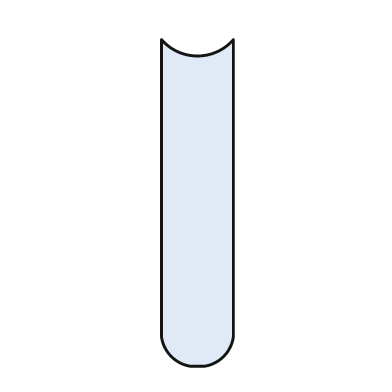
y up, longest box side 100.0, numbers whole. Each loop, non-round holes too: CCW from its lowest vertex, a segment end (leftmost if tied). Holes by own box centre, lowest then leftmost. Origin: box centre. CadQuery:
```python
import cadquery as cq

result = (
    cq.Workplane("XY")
    .moveTo(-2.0, -50.0)
    .lineTo(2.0, -50.0)
    .threePointArc((8.0, -47.0), (11.0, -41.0))
    .lineTo(11.0, 50.0)
    .threePointArc((0.0, 45.0), (-11.0, 50.0))
    .lineTo(-11.0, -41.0)
    .threePointArc((-8.0, -47.0), (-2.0, -50.0))
    .close()
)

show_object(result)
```